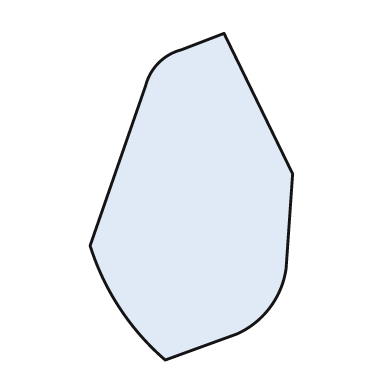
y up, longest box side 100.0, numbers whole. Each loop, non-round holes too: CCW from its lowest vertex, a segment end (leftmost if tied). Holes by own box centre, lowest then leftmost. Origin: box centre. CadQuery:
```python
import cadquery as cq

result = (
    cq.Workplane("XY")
    .moveTo(-8.0, -50.0)
    .lineTo(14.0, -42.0)
    .threePointArc((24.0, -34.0), (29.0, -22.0))
    .lineTo(31.0, 7.0)
    .lineTo(10.0, 50.0)
    .lineTo(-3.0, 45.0)
    .threePointArc((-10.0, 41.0), (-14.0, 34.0))
    .lineTo(-31.0, -15.0)
    .threePointArc((-22.0, -34.0), (-8.0, -50.0))
    .close()
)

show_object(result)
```